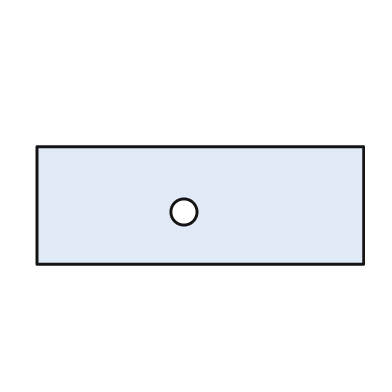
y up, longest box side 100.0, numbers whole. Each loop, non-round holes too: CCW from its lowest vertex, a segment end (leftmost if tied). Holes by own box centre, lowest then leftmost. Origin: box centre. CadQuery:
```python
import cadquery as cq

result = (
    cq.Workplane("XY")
    .moveTo(-50.0, -18.0)
    .lineTo(50.0, -18.0)
    .lineTo(50.0, 18.0)
    .lineTo(-50.0, 18.0)
    .close()
    .moveTo(-5.0, -2.0)
    .circle(4.0)
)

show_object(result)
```